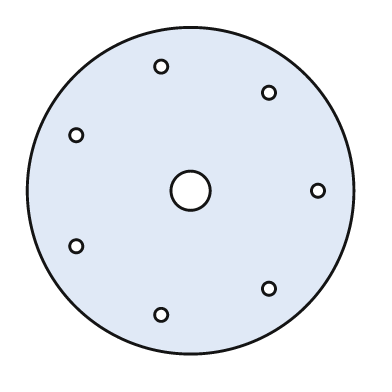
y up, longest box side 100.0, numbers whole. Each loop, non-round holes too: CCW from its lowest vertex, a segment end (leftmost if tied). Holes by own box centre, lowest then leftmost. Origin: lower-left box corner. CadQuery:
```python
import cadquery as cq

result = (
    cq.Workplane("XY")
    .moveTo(50.0, 50.0)
    .circle(50.0)
    .moveTo(41.0, 12.0)
    .circle(2.0)
    .moveTo(74.0, 20.0)
    .circle(2.0)
    .moveTo(15.0, 33.0)
    .circle(2.0)
    .moveTo(50.0, 50.0)
    .circle(6.0)
    .moveTo(89.0, 50.0)
    .circle(2.0)
    .moveTo(15.0, 67.0)
    .circle(2.0)
    .moveTo(74.0, 80.0)
    .circle(2.0)
    .moveTo(41.0, 88.0)
    .circle(2.0)
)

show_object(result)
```